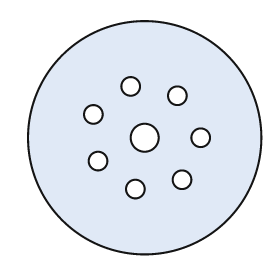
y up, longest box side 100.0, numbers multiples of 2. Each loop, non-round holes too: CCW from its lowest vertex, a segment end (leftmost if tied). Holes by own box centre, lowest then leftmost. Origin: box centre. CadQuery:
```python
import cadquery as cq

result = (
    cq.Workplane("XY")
    .moveTo(0.0, 0.0)
    .circle(50.0)
    .moveTo(-4.0, -22.0)
    .circle(4.0)
    .moveTo(16.0, -18.0)
    .circle(4.0)
    .moveTo(-20.0, -10.0)
    .circle(4.0)
    .moveTo(0.0, 0.0)
    .circle(6.0)
    .moveTo(24.0, 0.0)
    .circle(4.0)
    .moveTo(-22.0, 10.0)
    .circle(4.0)
    .moveTo(14.0, 18.0)
    .circle(4.0)
    .moveTo(-6.0, 22.0)
    .circle(4.0)
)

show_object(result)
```